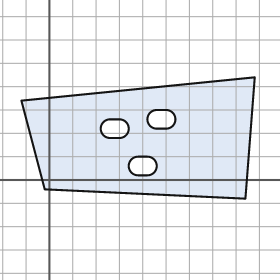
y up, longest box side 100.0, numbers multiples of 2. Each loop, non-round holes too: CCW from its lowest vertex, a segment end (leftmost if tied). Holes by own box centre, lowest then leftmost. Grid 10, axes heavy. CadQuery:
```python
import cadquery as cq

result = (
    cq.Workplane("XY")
    .moveTo(84.0, -8.0)
    .lineTo(88.0, 44.0)
    .lineTo(-12.0, 34.0)
    .lineTo(-2.0, -4.0)
    .close()
    .moveTo(38.0, 2.0)
    .lineTo(42.0, 2.0)
    .threePointArc((46.0, 6.0), (42.0, 10.0))
    .lineTo(38.0, 10.0)
    .threePointArc((34.0, 6.0), (38.0, 2.0))
    .close()
    .moveTo(26.0, 18.0)
    .lineTo(30.0, 18.0)
    .threePointArc((34.0, 22.0), (30.0, 26.0))
    .lineTo(26.0, 26.0)
    .threePointArc((22.0, 22.0), (26.0, 18.0))
    .close()
    .moveTo(46.0, 22.0)
    .lineTo(50.0, 22.0)
    .threePointArc((54.0, 26.0), (50.0, 30.0))
    .lineTo(46.0, 30.0)
    .threePointArc((42.0, 26.0), (46.0, 22.0))
    .close()
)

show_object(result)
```